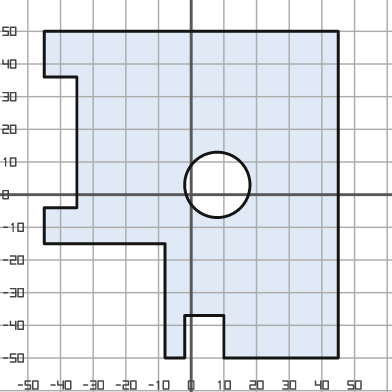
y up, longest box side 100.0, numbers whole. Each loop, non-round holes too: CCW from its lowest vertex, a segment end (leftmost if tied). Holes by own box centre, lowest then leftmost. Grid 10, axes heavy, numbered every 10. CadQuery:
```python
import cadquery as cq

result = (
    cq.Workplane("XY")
    .moveTo(-8.0, -50.0)
    .lineTo(-2.0, -50.0)
    .lineTo(-2.0, -37.0)
    .lineTo(10.0, -37.0)
    .lineTo(10.0, -50.0)
    .lineTo(45.0, -50.0)
    .lineTo(45.0, 50.0)
    .lineTo(-45.0, 50.0)
    .lineTo(-45.0, 36.0)
    .lineTo(-35.0, 36.0)
    .lineTo(-35.0, -4.0)
    .lineTo(-45.0, -4.0)
    .lineTo(-45.0, -15.0)
    .lineTo(-8.0, -15.0)
    .close()
    .moveTo(8.0, 3.0)
    .circle(10.0)
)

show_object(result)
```